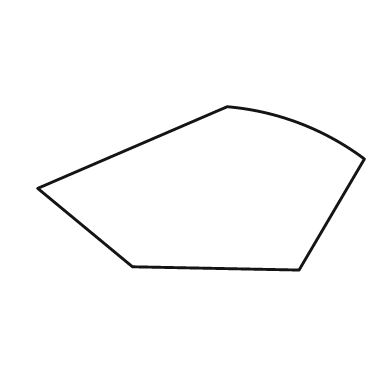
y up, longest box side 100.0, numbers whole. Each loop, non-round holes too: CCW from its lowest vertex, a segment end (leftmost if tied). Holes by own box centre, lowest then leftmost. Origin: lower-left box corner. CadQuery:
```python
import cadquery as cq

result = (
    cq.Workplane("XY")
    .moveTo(80.0, 0.0)
    .lineTo(100.0, 34.0)
    .threePointArc((80.0, 45.0), (58.0, 50.0))
    .lineTo(0.0, 25.0)
    .lineTo(29.0, 1.0)
    .close()
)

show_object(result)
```